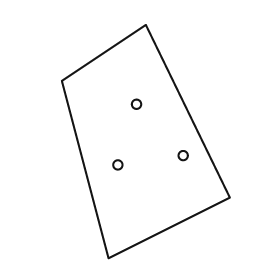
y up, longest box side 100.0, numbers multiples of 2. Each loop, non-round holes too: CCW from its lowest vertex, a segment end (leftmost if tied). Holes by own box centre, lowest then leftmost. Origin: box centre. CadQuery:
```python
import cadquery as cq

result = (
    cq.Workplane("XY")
    .moveTo(-16.0, -50.0)
    .lineTo(36.0, -24.0)
    .lineTo(0.0, 50.0)
    .lineTo(-36.0, 26.0)
    .close()
    .moveTo(-12.0, -10.0)
    .circle(2.0)
    .moveTo(16.0, -6.0)
    .circle(2.0)
    .moveTo(-4.0, 16.0)
    .circle(2.0)
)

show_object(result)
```